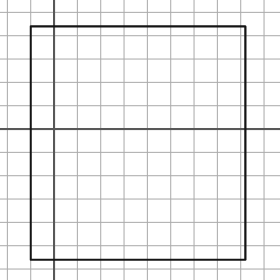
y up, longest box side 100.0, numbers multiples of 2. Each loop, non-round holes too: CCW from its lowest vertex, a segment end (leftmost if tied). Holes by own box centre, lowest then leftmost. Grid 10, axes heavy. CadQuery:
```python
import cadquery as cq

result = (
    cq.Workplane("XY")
    .moveTo(-10.0, -56.0)
    .lineTo(82.0, -56.0)
    .lineTo(82.0, 44.0)
    .lineTo(-10.0, 44.0)
    .close()
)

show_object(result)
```